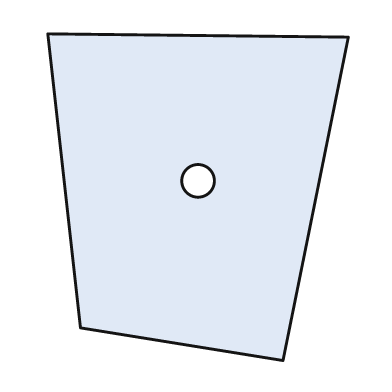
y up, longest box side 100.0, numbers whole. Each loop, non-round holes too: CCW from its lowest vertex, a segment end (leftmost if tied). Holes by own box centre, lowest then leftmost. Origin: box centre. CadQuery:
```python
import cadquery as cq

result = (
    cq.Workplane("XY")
    .moveTo(26.0, -50.0)
    .lineTo(46.0, 49.0)
    .lineTo(-46.0, 50.0)
    .lineTo(-36.0, -40.0)
    .close()
    .moveTo(0.0, 5.0)
    .circle(5.0)
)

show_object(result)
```